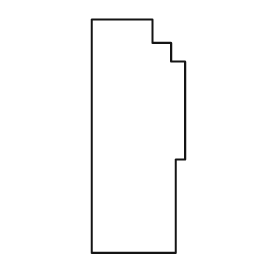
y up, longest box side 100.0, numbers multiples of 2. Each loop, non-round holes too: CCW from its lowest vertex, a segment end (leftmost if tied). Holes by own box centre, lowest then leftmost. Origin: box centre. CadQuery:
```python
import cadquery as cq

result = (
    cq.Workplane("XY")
    .moveTo(-20.0, -50.0)
    .lineTo(16.0, -50.0)
    .lineTo(16.0, -10.0)
    .lineTo(20.0, -10.0)
    .lineTo(20.0, 32.0)
    .lineTo(14.0, 32.0)
    .lineTo(14.0, 40.0)
    .lineTo(6.0, 40.0)
    .lineTo(6.0, 50.0)
    .lineTo(-20.0, 50.0)
    .close()
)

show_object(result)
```